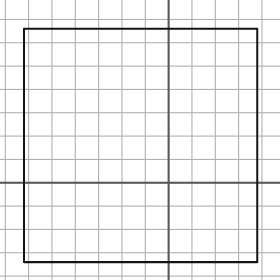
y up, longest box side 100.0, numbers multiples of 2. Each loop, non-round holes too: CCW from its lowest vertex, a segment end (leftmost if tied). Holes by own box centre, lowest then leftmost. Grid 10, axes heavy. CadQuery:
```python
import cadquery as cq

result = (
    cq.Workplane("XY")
    .moveTo(-62.0, -34.0)
    .lineTo(38.0, -34.0)
    .lineTo(38.0, 66.0)
    .lineTo(-62.0, 66.0)
    .close()
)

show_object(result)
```